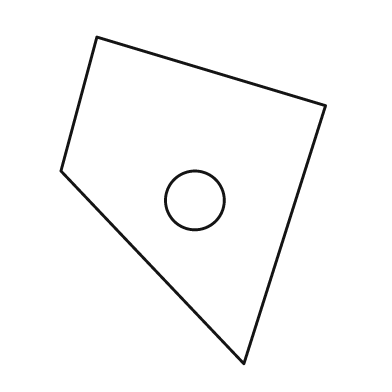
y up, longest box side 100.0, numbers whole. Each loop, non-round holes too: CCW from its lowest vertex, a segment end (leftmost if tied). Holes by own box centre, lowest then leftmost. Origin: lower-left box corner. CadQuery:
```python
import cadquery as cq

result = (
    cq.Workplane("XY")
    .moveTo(56.0, 0.0)
    .lineTo(81.0, 79.0)
    .lineTo(11.0, 100.0)
    .lineTo(0.0, 59.0)
    .close()
    .moveTo(41.0, 50.0)
    .circle(9.0)
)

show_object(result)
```